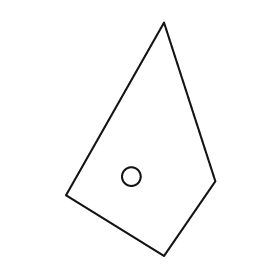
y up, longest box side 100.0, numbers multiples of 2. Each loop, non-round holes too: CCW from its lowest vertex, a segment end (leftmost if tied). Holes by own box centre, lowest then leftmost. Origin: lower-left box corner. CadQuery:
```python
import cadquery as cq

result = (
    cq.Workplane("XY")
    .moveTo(42.0, 0.0)
    .lineTo(64.0, 32.0)
    .lineTo(42.0, 100.0)
    .lineTo(0.0, 26.0)
    .close()
    .moveTo(28.0, 34.0)
    .circle(4.0)
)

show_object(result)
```